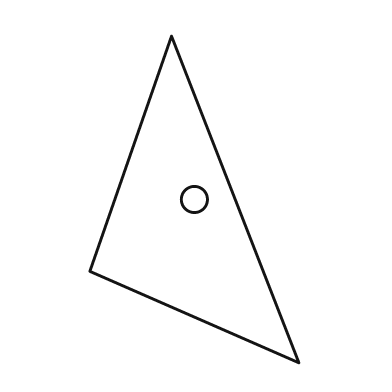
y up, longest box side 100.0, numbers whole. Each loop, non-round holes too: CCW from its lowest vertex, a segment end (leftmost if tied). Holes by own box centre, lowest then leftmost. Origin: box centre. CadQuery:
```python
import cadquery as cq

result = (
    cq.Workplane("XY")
    .moveTo(32.0, -50.0)
    .lineTo(-7.0, 50.0)
    .lineTo(-32.0, -22.0)
    .close()
    .moveTo(0.0, 0.0)
    .circle(4.0)
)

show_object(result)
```